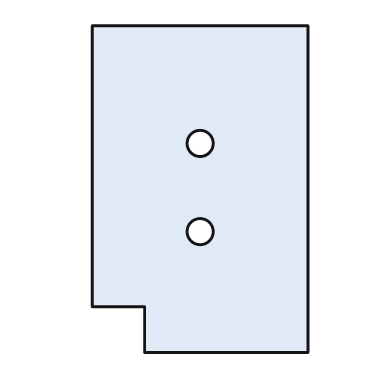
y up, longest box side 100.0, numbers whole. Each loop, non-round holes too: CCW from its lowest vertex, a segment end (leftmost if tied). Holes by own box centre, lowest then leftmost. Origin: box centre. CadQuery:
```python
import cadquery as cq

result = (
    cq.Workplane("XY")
    .moveTo(-17.0, -50.0)
    .lineTo(33.0, -50.0)
    .lineTo(33.0, 50.0)
    .lineTo(-33.0, 50.0)
    .lineTo(-33.0, -36.0)
    .lineTo(-17.0, -36.0)
    .close()
    .moveTo(0.0, -13.0)
    .circle(4.0)
    .moveTo(0.0, 14.0)
    .circle(4.0)
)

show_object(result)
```